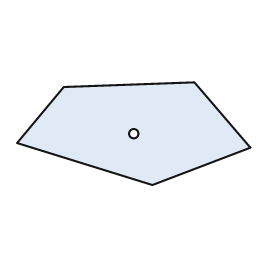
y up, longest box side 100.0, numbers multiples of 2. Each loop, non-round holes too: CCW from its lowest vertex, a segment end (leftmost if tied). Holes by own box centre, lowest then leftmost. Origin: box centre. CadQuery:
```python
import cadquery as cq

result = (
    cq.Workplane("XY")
    .moveTo(8.0, -22.0)
    .lineTo(50.0, -6.0)
    .lineTo(26.0, 22.0)
    .lineTo(-30.0, 20.0)
    .lineTo(-50.0, -4.0)
    .close()
    .moveTo(0.0, 0.0)
    .circle(2.0)
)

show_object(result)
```